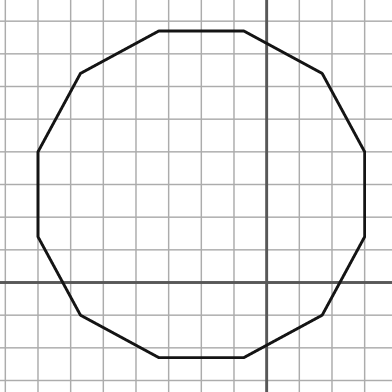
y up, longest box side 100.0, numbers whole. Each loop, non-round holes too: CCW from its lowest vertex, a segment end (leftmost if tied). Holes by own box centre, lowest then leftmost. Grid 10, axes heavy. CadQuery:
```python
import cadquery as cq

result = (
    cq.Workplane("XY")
    .moveTo(-33.0, -23.0)
    .lineTo(-7.0, -23.0)
    .lineTo(17.0, -10.0)
    .lineTo(30.0, 14.0)
    .lineTo(30.0, 40.0)
    .lineTo(17.0, 64.0)
    .lineTo(-7.0, 77.0)
    .lineTo(-33.0, 77.0)
    .lineTo(-57.0, 64.0)
    .lineTo(-70.0, 40.0)
    .lineTo(-70.0, 14.0)
    .lineTo(-57.0, -10.0)
    .close()
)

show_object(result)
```